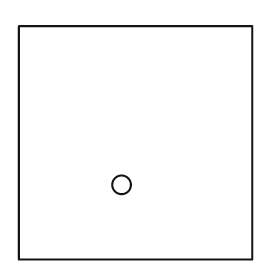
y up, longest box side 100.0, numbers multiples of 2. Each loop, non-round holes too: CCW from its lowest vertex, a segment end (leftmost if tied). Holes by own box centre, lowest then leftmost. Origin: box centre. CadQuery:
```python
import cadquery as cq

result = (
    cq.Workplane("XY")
    .moveTo(-50.0, -50.0)
    .lineTo(50.0, -50.0)
    .lineTo(50.0, 50.0)
    .lineTo(-50.0, 50.0)
    .close()
    .moveTo(-6.0, -18.0)
    .circle(4.0)
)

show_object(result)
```